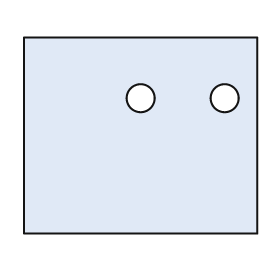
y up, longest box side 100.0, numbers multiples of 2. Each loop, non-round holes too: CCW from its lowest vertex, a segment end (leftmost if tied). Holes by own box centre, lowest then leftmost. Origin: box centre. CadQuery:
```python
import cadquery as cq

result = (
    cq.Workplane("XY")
    .moveTo(-50.0, -42.0)
    .lineTo(50.0, -42.0)
    .lineTo(50.0, 42.0)
    .lineTo(-50.0, 42.0)
    .close()
    .moveTo(0.0, 16.0)
    .circle(6.0)
    .moveTo(36.0, 16.0)
    .circle(6.0)
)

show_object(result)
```